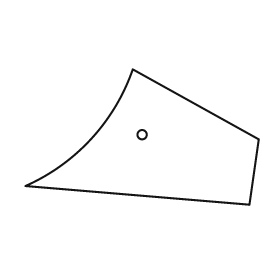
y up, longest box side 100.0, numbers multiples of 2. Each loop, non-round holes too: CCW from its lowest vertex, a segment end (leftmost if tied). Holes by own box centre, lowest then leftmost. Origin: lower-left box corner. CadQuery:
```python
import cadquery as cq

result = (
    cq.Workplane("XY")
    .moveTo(96.0, 0.0)
    .lineTo(100.0, 28.0)
    .lineTo(46.0, 58.0)
    .threePointArc((28.0, 28.0), (0.0, 8.0))
    .close()
    .moveTo(50.0, 30.0)
    .circle(2.0)
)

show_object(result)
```